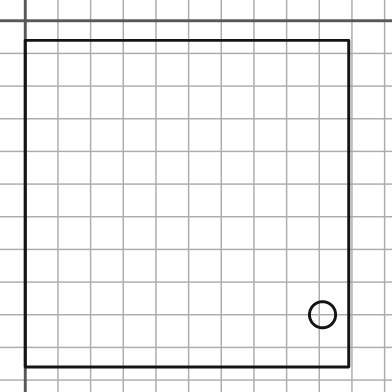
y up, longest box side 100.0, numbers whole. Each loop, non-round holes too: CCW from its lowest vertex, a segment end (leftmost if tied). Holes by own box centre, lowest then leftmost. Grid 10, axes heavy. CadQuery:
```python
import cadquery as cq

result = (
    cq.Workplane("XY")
    .moveTo(0.0, -106.0)
    .lineTo(99.0, -106.0)
    .lineTo(99.0, -6.0)
    .lineTo(0.0, -6.0)
    .close()
    .moveTo(91.0, -90.0)
    .circle(4.0)
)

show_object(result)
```